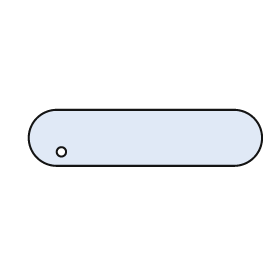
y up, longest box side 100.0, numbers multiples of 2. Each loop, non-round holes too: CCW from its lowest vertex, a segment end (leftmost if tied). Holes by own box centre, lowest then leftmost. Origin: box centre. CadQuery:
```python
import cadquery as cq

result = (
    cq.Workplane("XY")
    .moveTo(-38.0, -12.0)
    .lineTo(38.0, -12.0)
    .threePointArc((50.0, 0.0), (38.0, 12.0))
    .lineTo(-38.0, 12.0)
    .threePointArc((-50.0, 0.0), (-38.0, -12.0))
    .close()
    .moveTo(-36.0, -6.0)
    .circle(2.0)
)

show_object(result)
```